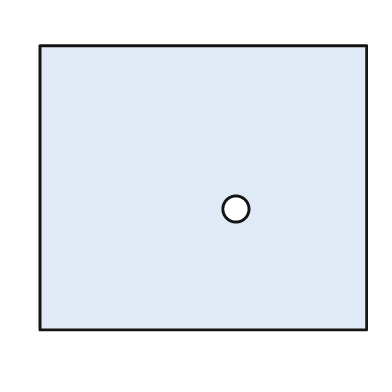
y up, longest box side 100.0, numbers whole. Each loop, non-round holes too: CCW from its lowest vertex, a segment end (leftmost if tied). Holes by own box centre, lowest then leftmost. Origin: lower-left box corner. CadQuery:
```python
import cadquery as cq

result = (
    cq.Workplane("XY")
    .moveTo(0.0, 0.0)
    .lineTo(100.0, 0.0)
    .lineTo(100.0, 87.0)
    .lineTo(0.0, 87.0)
    .close()
    .moveTo(60.0, 37.0)
    .circle(4.0)
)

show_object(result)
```